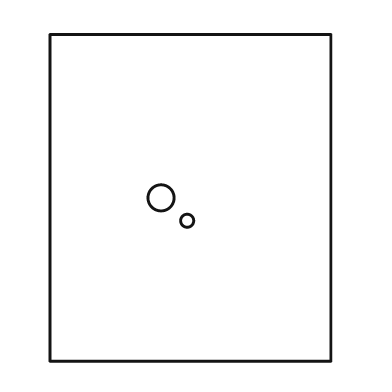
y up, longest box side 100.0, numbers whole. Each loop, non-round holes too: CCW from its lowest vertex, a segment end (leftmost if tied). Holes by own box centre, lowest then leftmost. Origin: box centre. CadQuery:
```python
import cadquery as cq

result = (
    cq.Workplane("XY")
    .moveTo(-43.0, -50.0)
    .lineTo(43.0, -50.0)
    .lineTo(43.0, 50.0)
    .lineTo(-43.0, 50.0)
    .close()
    .moveTo(-1.0, -7.0)
    .circle(2.0)
    .moveTo(-9.0, 0.0)
    .circle(4.0)
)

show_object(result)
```